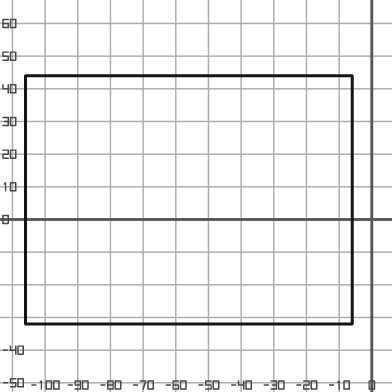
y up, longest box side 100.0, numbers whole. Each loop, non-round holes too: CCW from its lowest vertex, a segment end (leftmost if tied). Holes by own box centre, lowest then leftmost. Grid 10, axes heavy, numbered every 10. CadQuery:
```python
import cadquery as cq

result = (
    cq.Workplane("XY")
    .moveTo(-106.0, -32.0)
    .lineTo(-6.0, -32.0)
    .lineTo(-6.0, 44.0)
    .lineTo(-106.0, 44.0)
    .close()
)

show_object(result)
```